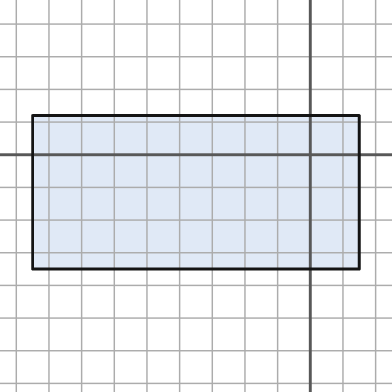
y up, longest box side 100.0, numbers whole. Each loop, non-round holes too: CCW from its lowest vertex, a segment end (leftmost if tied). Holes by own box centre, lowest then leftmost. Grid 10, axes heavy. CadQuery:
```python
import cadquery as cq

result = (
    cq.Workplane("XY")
    .moveTo(-85.0, -35.0)
    .lineTo(15.0, -35.0)
    .lineTo(15.0, 12.0)
    .lineTo(-85.0, 12.0)
    .close()
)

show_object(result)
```